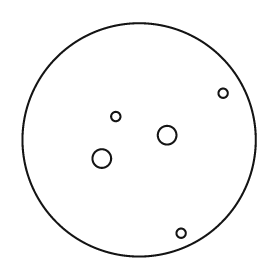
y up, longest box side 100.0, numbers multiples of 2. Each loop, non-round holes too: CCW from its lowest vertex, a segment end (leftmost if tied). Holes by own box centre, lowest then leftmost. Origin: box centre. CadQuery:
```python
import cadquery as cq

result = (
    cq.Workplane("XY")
    .moveTo(0.0, 0.0)
    .circle(50.0)
    .moveTo(18.0, -40.0)
    .circle(2.0)
    .moveTo(-16.0, -8.0)
    .circle(4.0)
    .moveTo(12.0, 2.0)
    .circle(4.0)
    .moveTo(-10.0, 10.0)
    .circle(2.0)
    .moveTo(36.0, 20.0)
    .circle(2.0)
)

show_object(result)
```